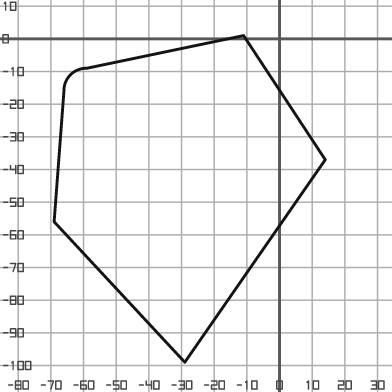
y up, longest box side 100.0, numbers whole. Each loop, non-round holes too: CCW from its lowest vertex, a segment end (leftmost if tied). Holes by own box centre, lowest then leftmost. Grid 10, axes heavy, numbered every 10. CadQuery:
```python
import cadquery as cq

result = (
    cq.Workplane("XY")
    .moveTo(-29.0, -99.0)
    .lineTo(14.0, -37.0)
    .lineTo(-11.0, 1.0)
    .lineTo(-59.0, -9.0)
    .threePointArc((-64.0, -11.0), (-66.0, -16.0))
    .lineTo(-69.0, -56.0)
    .close()
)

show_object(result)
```